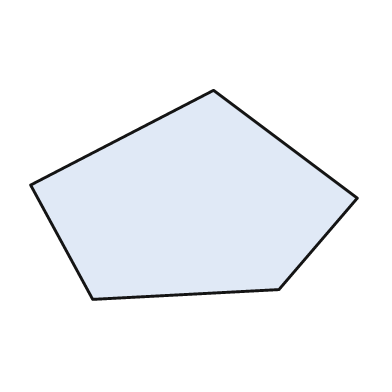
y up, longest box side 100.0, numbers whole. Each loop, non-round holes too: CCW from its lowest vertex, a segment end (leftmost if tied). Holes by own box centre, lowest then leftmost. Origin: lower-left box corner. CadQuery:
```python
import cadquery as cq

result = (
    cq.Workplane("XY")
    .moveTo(19.0, 0.0)
    .lineTo(76.0, 3.0)
    .lineTo(100.0, 31.0)
    .lineTo(56.0, 64.0)
    .lineTo(0.0, 35.0)
    .close()
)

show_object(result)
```